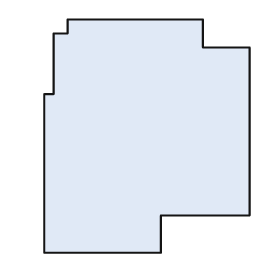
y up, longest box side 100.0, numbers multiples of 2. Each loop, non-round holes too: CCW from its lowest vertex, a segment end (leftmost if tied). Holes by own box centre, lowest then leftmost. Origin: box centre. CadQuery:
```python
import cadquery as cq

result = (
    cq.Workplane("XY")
    .moveTo(-44.0, -50.0)
    .lineTo(6.0, -50.0)
    .lineTo(6.0, -34.0)
    .lineTo(44.0, -34.0)
    .lineTo(44.0, 38.0)
    .lineTo(24.0, 38.0)
    .lineTo(24.0, 50.0)
    .lineTo(-34.0, 50.0)
    .lineTo(-34.0, 44.0)
    .lineTo(-40.0, 44.0)
    .lineTo(-40.0, 18.0)
    .lineTo(-44.0, 18.0)
    .close()
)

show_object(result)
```